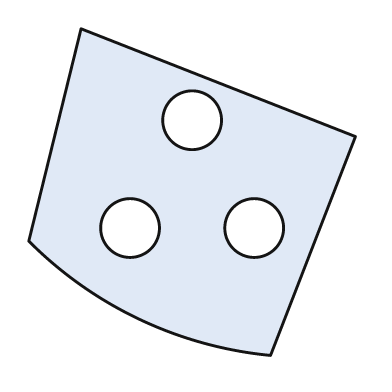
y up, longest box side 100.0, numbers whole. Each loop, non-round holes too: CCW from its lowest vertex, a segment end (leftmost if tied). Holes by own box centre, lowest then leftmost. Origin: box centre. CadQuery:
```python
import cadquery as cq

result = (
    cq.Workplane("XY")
    .moveTo(24.0, -50.0)
    .lineTo(50.0, 17.0)
    .lineTo(-34.0, 50.0)
    .lineTo(-50.0, -15.0)
    .threePointArc((-16.0, -39.0), (24.0, -50.0))
    .close()
    .moveTo(-19.0, -11.0)
    .circle(9.0)
    .moveTo(19.0, -11.0)
    .circle(9.0)
    .moveTo(0.0, 22.0)
    .circle(9.0)
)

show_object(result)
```